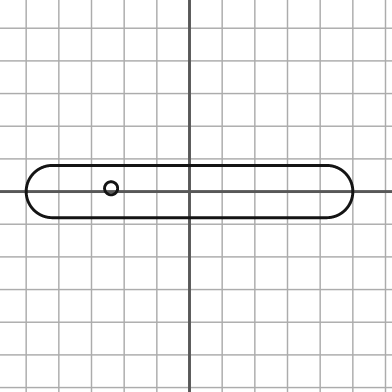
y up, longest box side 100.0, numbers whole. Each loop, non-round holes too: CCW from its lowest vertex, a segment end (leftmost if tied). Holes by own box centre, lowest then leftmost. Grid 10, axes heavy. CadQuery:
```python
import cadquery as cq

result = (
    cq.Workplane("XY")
    .moveTo(-42.0, -8.0)
    .lineTo(42.0, -8.0)
    .threePointArc((50.0, 0.0), (42.0, 8.0))
    .lineTo(-42.0, 8.0)
    .threePointArc((-50.0, 0.0), (-42.0, -8.0))
    .close()
    .moveTo(-24.0, 1.0)
    .circle(2.0)
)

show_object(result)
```